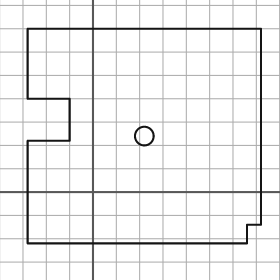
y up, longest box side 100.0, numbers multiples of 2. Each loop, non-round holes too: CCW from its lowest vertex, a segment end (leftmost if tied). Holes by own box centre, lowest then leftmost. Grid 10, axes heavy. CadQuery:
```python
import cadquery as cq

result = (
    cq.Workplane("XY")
    .moveTo(-28.0, -22.0)
    .lineTo(66.0, -22.0)
    .lineTo(66.0, -14.0)
    .lineTo(72.0, -14.0)
    .lineTo(72.0, 70.0)
    .lineTo(-28.0, 70.0)
    .lineTo(-28.0, 40.0)
    .lineTo(-10.0, 40.0)
    .lineTo(-10.0, 22.0)
    .lineTo(-28.0, 22.0)
    .close()
    .moveTo(22.0, 24.0)
    .circle(4.0)
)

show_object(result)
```